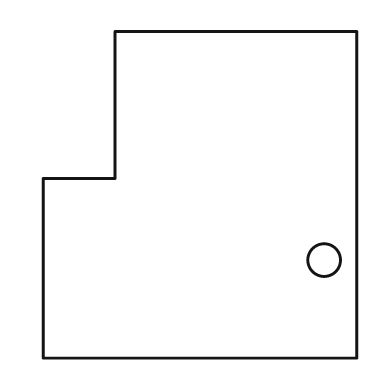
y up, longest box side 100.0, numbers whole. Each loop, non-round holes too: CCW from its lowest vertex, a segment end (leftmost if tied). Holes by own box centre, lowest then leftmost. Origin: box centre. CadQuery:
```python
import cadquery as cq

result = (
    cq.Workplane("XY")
    .moveTo(-48.0, -50.0)
    .lineTo(48.0, -50.0)
    .lineTo(48.0, 50.0)
    .lineTo(-26.0, 50.0)
    .lineTo(-26.0, 5.0)
    .lineTo(-48.0, 5.0)
    .close()
    .moveTo(38.0, -20.0)
    .circle(5.0)
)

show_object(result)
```